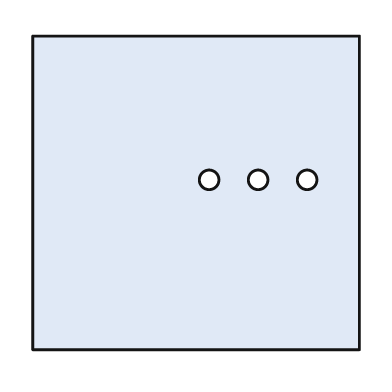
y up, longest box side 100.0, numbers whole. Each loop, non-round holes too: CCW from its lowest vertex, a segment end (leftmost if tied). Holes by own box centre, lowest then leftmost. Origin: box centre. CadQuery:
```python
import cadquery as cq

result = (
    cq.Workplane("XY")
    .moveTo(-50.0, -48.0)
    .lineTo(50.0, -48.0)
    .lineTo(50.0, 48.0)
    .lineTo(-50.0, 48.0)
    .close()
    .moveTo(4.0, 4.0)
    .circle(3.0)
    .moveTo(19.0, 4.0)
    .circle(3.0)
    .moveTo(34.0, 4.0)
    .circle(3.0)
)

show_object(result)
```